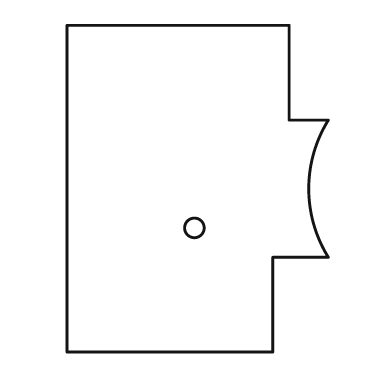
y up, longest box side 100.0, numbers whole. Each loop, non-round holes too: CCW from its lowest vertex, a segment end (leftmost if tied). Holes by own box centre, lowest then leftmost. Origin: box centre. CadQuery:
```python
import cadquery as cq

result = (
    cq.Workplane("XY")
    .moveTo(-40.0, -50.0)
    .lineTo(23.0, -50.0)
    .lineTo(23.0, -21.0)
    .lineTo(40.0, -21.0)
    .threePointArc((34.0, 0.0), (40.0, 21.0))
    .lineTo(28.0, 21.0)
    .lineTo(28.0, 50.0)
    .lineTo(-40.0, 50.0)
    .close()
    .moveTo(-1.0, -12.0)
    .circle(3.0)
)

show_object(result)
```